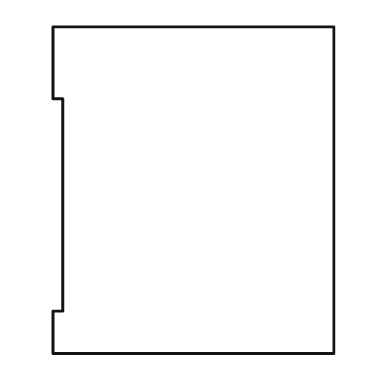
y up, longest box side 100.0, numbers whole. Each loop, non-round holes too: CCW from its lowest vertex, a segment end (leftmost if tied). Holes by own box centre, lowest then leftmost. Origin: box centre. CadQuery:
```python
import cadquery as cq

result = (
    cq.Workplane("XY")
    .moveTo(-43.0, -50.0)
    .lineTo(43.0, -50.0)
    .lineTo(43.0, 50.0)
    .lineTo(-43.0, 50.0)
    .lineTo(-43.0, 28.0)
    .lineTo(-40.0, 28.0)
    .lineTo(-40.0, -37.0)
    .lineTo(-43.0, -37.0)
    .close()
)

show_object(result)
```